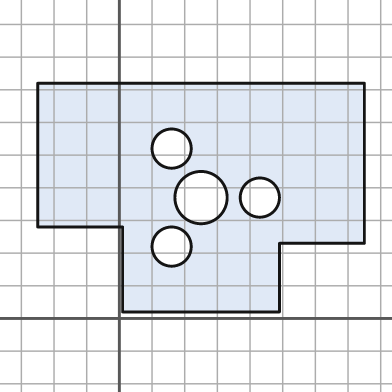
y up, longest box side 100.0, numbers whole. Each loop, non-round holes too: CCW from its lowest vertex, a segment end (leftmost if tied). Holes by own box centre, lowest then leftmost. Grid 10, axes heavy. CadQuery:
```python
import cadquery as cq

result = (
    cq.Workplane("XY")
    .moveTo(1.0, 2.0)
    .lineTo(49.0, 2.0)
    .lineTo(49.0, 23.0)
    .lineTo(75.0, 23.0)
    .lineTo(75.0, 72.0)
    .lineTo(-25.0, 72.0)
    .lineTo(-25.0, 28.0)
    .lineTo(1.0, 28.0)
    .close()
    .moveTo(16.0, 22.0)
    .circle(6.0)
    .moveTo(25.0, 37.0)
    .circle(8.0)
    .moveTo(43.0, 37.0)
    .circle(6.0)
    .moveTo(16.0, 52.0)
    .circle(6.0)
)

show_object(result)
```